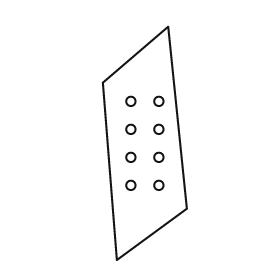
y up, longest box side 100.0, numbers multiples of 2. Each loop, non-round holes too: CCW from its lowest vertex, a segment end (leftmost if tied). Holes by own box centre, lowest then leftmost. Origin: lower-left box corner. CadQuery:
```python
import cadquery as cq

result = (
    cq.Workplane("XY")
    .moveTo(6.0, 0.0)
    .lineTo(36.0, 22.0)
    .lineTo(28.0, 100.0)
    .lineTo(0.0, 76.0)
    .close()
    .moveTo(12.0, 32.0)
    .circle(2.0)
    .moveTo(24.0, 32.0)
    .circle(2.0)
    .moveTo(12.0, 44.0)
    .circle(2.0)
    .moveTo(24.0, 44.0)
    .circle(2.0)
    .moveTo(12.0, 56.0)
    .circle(2.0)
    .moveTo(24.0, 56.0)
    .circle(2.0)
    .moveTo(12.0, 68.0)
    .circle(2.0)
    .moveTo(24.0, 68.0)
    .circle(2.0)
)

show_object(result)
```